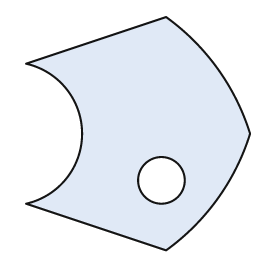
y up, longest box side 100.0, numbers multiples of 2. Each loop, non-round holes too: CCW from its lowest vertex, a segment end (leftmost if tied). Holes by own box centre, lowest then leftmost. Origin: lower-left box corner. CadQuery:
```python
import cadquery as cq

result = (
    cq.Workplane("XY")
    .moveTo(60.0, 0.0)
    .threePointArc((82.0, 22.0), (96.0, 50.0))
    .threePointArc((82.0, 78.0), (60.0, 100.0))
    .lineTo(0.0, 80.0)
    .threePointArc((24.0, 50.0), (0.0, 20.0))
    .close()
    .moveTo(58.0, 30.0)
    .circle(10.0)
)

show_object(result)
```